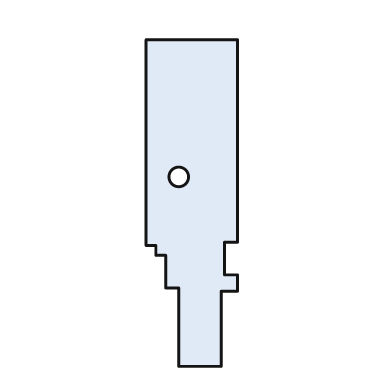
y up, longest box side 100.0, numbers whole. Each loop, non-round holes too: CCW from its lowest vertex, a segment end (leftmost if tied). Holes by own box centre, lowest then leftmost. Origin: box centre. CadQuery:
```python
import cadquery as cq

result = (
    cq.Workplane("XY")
    .moveTo(-4.0, -50.0)
    .lineTo(9.0, -50.0)
    .lineTo(9.0, -27.0)
    .lineTo(14.0, -27.0)
    .lineTo(14.0, -22.0)
    .lineTo(10.0, -22.0)
    .lineTo(10.0, -12.0)
    .lineTo(14.0, -12.0)
    .lineTo(14.0, 50.0)
    .lineTo(-14.0, 50.0)
    .lineTo(-14.0, -13.0)
    .lineTo(-11.0, -13.0)
    .lineTo(-11.0, -16.0)
    .lineTo(-8.0, -16.0)
    .lineTo(-8.0, -26.0)
    .lineTo(-4.0, -26.0)
    .close()
    .moveTo(-4.0, 8.0)
    .circle(3.0)
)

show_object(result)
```